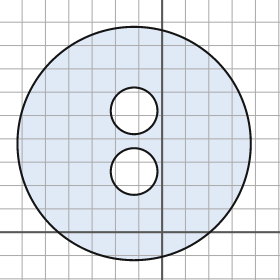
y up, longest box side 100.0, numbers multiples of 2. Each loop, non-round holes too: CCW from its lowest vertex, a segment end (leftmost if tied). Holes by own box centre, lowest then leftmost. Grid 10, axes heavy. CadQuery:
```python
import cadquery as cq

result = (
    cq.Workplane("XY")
    .moveTo(-12.0, 38.0)
    .circle(50.0)
    .moveTo(-12.0, 26.0)
    .circle(10.0)
    .moveTo(-12.0, 52.0)
    .circle(10.0)
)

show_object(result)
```